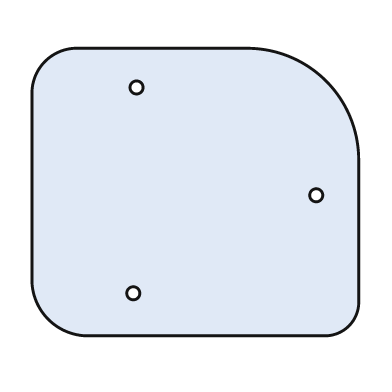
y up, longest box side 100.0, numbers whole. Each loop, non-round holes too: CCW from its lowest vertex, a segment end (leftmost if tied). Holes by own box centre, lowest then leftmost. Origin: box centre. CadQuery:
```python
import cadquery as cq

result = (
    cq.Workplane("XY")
    .moveTo(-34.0, -44.0)
    .lineTo(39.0, -44.0)
    .threePointArc((47.0, -41.0), (50.0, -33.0))
    .lineTo(50.0, 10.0)
    .threePointArc((40.0, 34.0), (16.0, 44.0))
    .lineTo(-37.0, 44.0)
    .threePointArc((-46.0, 40.0), (-50.0, 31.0))
    .lineTo(-50.0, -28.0)
    .threePointArc((-45.0, -39.0), (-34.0, -44.0))
    .close()
    .moveTo(-19.0, -31.0)
    .circle(2.0)
    .moveTo(37.0, -1.0)
    .circle(2.0)
    .moveTo(-18.0, 32.0)
    .circle(2.0)
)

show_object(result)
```